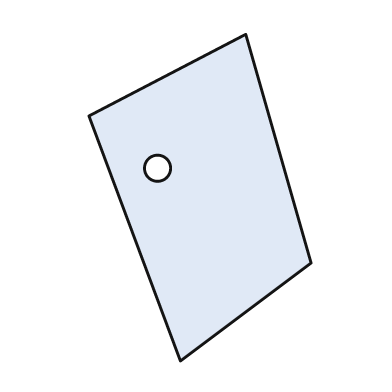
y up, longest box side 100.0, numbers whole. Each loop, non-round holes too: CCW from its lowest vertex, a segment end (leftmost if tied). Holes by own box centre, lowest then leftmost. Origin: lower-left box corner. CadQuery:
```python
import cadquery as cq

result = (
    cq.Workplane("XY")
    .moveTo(28.0, 0.0)
    .lineTo(68.0, 30.0)
    .lineTo(48.0, 100.0)
    .lineTo(0.0, 75.0)
    .close()
    .moveTo(21.0, 59.0)
    .circle(4.0)
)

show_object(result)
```